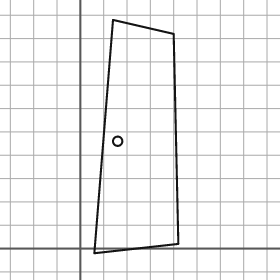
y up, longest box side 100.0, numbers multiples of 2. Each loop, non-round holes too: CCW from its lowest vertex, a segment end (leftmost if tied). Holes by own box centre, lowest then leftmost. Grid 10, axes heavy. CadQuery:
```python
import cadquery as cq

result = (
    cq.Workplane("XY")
    .moveTo(6.0, -2.0)
    .lineTo(42.0, 2.0)
    .lineTo(40.0, 92.0)
    .lineTo(14.0, 98.0)
    .close()
    .moveTo(16.0, 46.0)
    .circle(2.0)
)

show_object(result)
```